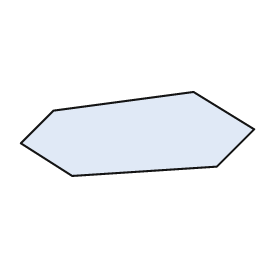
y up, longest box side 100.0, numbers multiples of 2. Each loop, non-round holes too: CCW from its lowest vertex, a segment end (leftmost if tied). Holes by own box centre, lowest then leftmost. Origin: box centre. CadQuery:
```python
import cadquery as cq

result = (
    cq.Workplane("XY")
    .moveTo(-28.0, -18.0)
    .lineTo(34.0, -14.0)
    .lineTo(50.0, 2.0)
    .lineTo(24.0, 18.0)
    .lineTo(-36.0, 10.0)
    .lineTo(-50.0, -4.0)
    .close()
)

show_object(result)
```